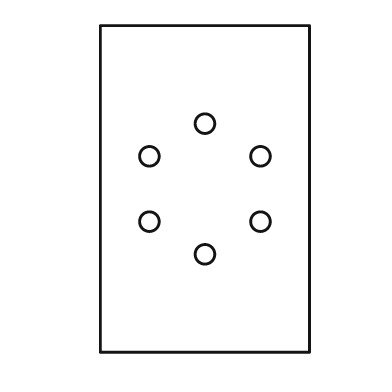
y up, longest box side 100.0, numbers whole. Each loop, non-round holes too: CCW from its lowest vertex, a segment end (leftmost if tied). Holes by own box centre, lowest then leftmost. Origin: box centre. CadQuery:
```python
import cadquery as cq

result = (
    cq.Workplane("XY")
    .moveTo(-32.0, -50.0)
    .lineTo(32.0, -50.0)
    .lineTo(32.0, 50.0)
    .lineTo(-32.0, 50.0)
    .close()
    .moveTo(0.0, -20.0)
    .circle(3.0)
    .moveTo(-17.0, -10.0)
    .circle(3.0)
    .moveTo(17.0, -10.0)
    .circle(3.0)
    .moveTo(-17.0, 10.0)
    .circle(3.0)
    .moveTo(17.0, 10.0)
    .circle(3.0)
    .moveTo(0.0, 20.0)
    .circle(3.0)
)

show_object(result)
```